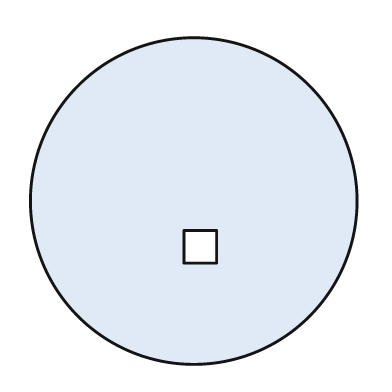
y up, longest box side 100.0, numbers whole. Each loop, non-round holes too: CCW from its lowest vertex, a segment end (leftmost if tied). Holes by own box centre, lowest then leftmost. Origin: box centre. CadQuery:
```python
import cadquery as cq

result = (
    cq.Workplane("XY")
    .moveTo(0.0, 0.0)
    .circle(50.0)
    .moveTo(-3.0, -19.0)
    .lineTo(7.0, -19.0)
    .lineTo(7.0, -9.0)
    .lineTo(-3.0, -9.0)
    .close()
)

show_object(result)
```